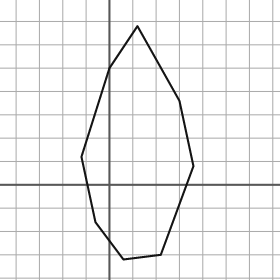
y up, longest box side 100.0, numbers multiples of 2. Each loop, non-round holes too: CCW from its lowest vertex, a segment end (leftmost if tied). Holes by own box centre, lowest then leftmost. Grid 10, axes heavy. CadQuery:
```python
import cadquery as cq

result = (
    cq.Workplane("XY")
    .moveTo(6.0, -32.0)
    .lineTo(22.0, -30.0)
    .lineTo(36.0, 8.0)
    .lineTo(30.0, 36.0)
    .lineTo(12.0, 68.0)
    .lineTo(0.0, 50.0)
    .lineTo(-12.0, 12.0)
    .lineTo(-6.0, -16.0)
    .close()
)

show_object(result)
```